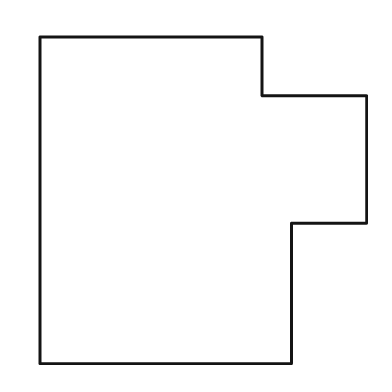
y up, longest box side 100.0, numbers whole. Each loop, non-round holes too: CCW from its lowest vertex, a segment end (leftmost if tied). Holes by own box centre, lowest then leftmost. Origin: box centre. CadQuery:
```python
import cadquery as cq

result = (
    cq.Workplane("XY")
    .moveTo(-50.0, -50.0)
    .lineTo(27.0, -50.0)
    .lineTo(27.0, -7.0)
    .lineTo(50.0, -7.0)
    .lineTo(50.0, 32.0)
    .lineTo(18.0, 32.0)
    .lineTo(18.0, 50.0)
    .lineTo(-50.0, 50.0)
    .close()
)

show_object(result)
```